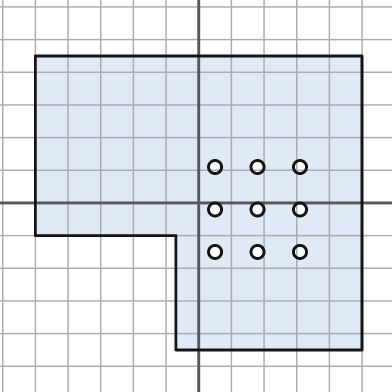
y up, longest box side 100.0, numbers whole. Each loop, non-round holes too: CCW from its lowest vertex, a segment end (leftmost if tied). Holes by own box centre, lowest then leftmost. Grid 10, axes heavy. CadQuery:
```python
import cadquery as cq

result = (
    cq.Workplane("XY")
    .moveTo(-7.0, -45.0)
    .lineTo(50.0, -45.0)
    .lineTo(50.0, 45.0)
    .lineTo(-50.0, 45.0)
    .lineTo(-50.0, -10.0)
    .lineTo(-7.0, -10.0)
    .close()
    .moveTo(5.0, -15.0)
    .circle(2.0)
    .moveTo(18.0, -15.0)
    .circle(2.0)
    .moveTo(31.0, -15.0)
    .circle(2.0)
    .moveTo(5.0, -2.0)
    .circle(2.0)
    .moveTo(18.0, -2.0)
    .circle(2.0)
    .moveTo(31.0, -2.0)
    .circle(2.0)
    .moveTo(5.0, 11.0)
    .circle(2.0)
    .moveTo(18.0, 11.0)
    .circle(2.0)
    .moveTo(31.0, 11.0)
    .circle(2.0)
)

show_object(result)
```